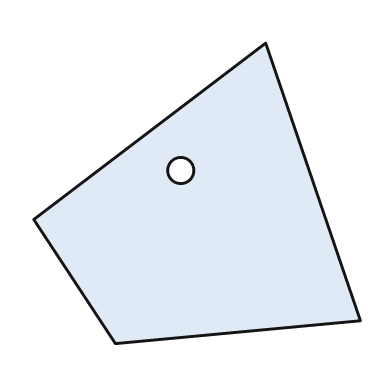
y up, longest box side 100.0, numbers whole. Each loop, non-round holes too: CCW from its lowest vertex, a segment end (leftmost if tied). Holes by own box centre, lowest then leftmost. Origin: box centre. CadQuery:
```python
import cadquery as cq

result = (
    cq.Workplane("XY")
    .moveTo(-25.0, -46.0)
    .lineTo(50.0, -39.0)
    .lineTo(21.0, 46.0)
    .lineTo(-50.0, -8.0)
    .close()
    .moveTo(-5.0, 7.0)
    .circle(4.0)
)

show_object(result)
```